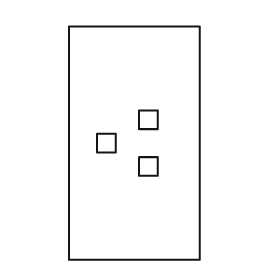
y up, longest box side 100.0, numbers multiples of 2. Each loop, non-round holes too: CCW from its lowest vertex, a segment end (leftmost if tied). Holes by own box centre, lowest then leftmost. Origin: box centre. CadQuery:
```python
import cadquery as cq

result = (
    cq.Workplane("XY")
    .moveTo(-28.0, -50.0)
    .lineTo(28.0, -50.0)
    .lineTo(28.0, 50.0)
    .lineTo(-28.0, 50.0)
    .close()
    .moveTo(2.0, -14.0)
    .lineTo(10.0, -14.0)
    .lineTo(10.0, -6.0)
    .lineTo(2.0, -6.0)
    .close()
    .moveTo(-16.0, -4.0)
    .lineTo(-8.0, -4.0)
    .lineTo(-8.0, 4.0)
    .lineTo(-16.0, 4.0)
    .close()
    .moveTo(2.0, 6.0)
    .lineTo(10.0, 6.0)
    .lineTo(10.0, 14.0)
    .lineTo(2.0, 14.0)
    .close()
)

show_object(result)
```